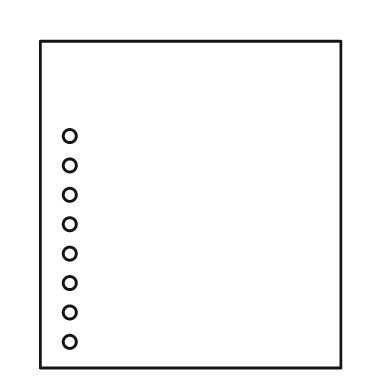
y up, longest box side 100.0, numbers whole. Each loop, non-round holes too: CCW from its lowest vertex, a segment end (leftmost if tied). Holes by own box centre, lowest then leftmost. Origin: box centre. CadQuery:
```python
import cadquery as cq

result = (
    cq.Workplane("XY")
    .moveTo(-46.0, -50.0)
    .lineTo(46.0, -50.0)
    .lineTo(46.0, 50.0)
    .lineTo(-46.0, 50.0)
    .close()
    .moveTo(-37.0, -42.0)
    .circle(2.0)
    .moveTo(-37.0, -33.0)
    .circle(2.0)
    .moveTo(-37.0, -24.0)
    .circle(2.0)
    .moveTo(-37.0, -15.0)
    .circle(2.0)
    .moveTo(-37.0, -6.0)
    .circle(2.0)
    .moveTo(-37.0, 3.0)
    .circle(2.0)
    .moveTo(-37.0, 12.0)
    .circle(2.0)
    .moveTo(-37.0, 21.0)
    .circle(2.0)
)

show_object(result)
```